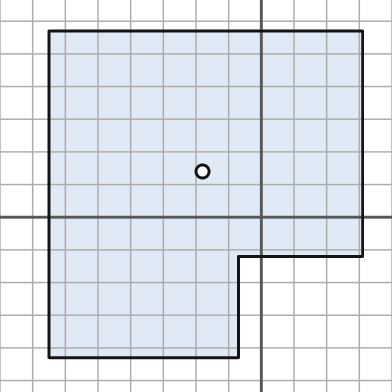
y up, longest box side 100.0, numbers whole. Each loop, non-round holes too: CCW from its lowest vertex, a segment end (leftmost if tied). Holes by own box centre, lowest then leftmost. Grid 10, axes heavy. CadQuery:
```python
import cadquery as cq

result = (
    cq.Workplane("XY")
    .moveTo(-65.0, -43.0)
    .lineTo(-7.0, -43.0)
    .lineTo(-7.0, -12.0)
    .lineTo(31.0, -12.0)
    .lineTo(31.0, 57.0)
    .lineTo(-65.0, 57.0)
    .close()
    .moveTo(-18.0, 14.0)
    .circle(2.0)
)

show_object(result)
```